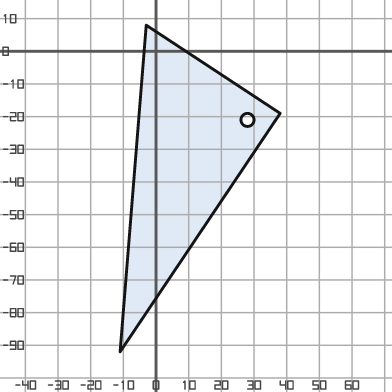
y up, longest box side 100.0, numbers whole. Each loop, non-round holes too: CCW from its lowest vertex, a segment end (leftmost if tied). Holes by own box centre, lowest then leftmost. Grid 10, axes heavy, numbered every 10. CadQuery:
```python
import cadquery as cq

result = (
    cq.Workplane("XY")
    .moveTo(-11.0, -92.0)
    .lineTo(38.0, -19.0)
    .lineTo(-3.0, 8.0)
    .close()
    .moveTo(28.0, -21.0)
    .circle(2.0)
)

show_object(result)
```